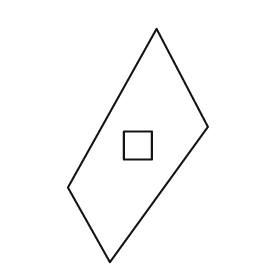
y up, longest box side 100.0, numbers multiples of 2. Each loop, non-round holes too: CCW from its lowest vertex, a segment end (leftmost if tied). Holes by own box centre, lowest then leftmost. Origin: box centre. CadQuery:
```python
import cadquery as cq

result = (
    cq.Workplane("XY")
    .moveTo(-12.0, -50.0)
    .lineTo(30.0, 8.0)
    .lineTo(8.0, 50.0)
    .lineTo(-30.0, -18.0)
    .close()
    .moveTo(-6.0, -6.0)
    .lineTo(6.0, -6.0)
    .lineTo(6.0, 6.0)
    .lineTo(-6.0, 6.0)
    .close()
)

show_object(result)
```